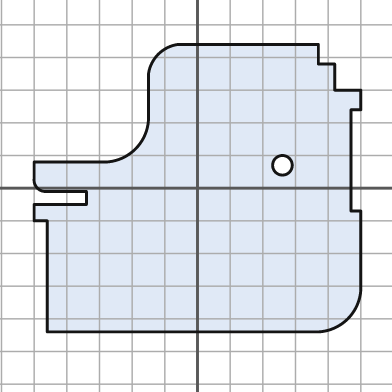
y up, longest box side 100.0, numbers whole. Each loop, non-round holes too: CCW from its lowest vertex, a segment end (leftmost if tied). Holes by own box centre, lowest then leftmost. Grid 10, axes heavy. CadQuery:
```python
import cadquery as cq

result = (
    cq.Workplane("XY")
    .moveTo(-46.0, -44.0)
    .lineTo(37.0, -44.0)
    .threePointArc((46.0, -40.0), (50.0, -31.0))
    .lineTo(50.0, -7.0)
    .lineTo(47.0, -7.0)
    .lineTo(47.0, 24.0)
    .lineTo(50.0, 24.0)
    .lineTo(50.0, 30.0)
    .lineTo(42.0, 30.0)
    .lineTo(42.0, 38.0)
    .lineTo(37.0, 38.0)
    .lineTo(37.0, 44.0)
    .lineTo(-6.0, 44.0)
    .threePointArc((-12.0, 41.0), (-15.0, 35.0))
    .lineTo(-15.0, 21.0)
    .threePointArc((-19.0, 12.0), (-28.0, 8.0))
    .lineTo(-50.0, 8.0)
    .lineTo(-50.0, 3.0)
    .threePointArc((-49.0, 0.0), (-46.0, -1.0))
    .lineTo(-34.0, -1.0)
    .lineTo(-34.0, -5.0)
    .lineTo(-50.0, -5.0)
    .lineTo(-50.0, -10.0)
    .lineTo(-46.0, -10.0)
    .close()
    .moveTo(26.0, 7.0)
    .circle(3.0)
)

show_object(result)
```